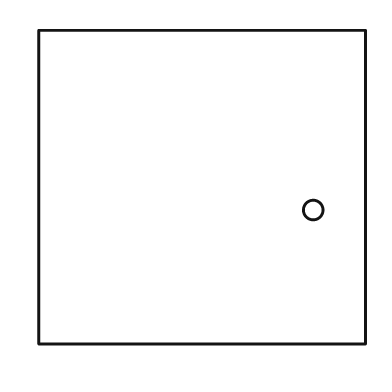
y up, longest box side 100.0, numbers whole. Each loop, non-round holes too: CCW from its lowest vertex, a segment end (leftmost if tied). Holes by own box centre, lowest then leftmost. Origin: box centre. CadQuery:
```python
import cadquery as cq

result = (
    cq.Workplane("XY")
    .moveTo(-50.0, -48.0)
    .lineTo(50.0, -48.0)
    .lineTo(50.0, 48.0)
    .lineTo(-50.0, 48.0)
    .close()
    .moveTo(34.0, -7.0)
    .circle(3.0)
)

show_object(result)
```